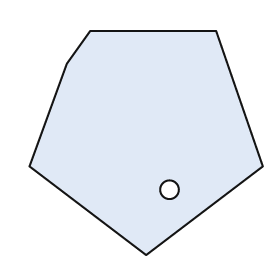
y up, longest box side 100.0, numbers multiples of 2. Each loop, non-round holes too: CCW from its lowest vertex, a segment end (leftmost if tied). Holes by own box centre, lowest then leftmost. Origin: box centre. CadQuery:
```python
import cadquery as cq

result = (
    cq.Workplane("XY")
    .moveTo(0.0, -48.0)
    .lineTo(50.0, -10.0)
    .lineTo(30.0, 48.0)
    .lineTo(-24.0, 48.0)
    .lineTo(-34.0, 34.0)
    .lineTo(-50.0, -10.0)
    .close()
    .moveTo(10.0, -20.0)
    .circle(4.0)
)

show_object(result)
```